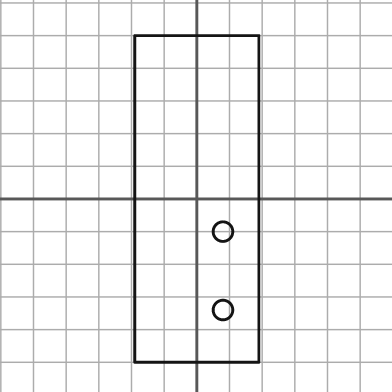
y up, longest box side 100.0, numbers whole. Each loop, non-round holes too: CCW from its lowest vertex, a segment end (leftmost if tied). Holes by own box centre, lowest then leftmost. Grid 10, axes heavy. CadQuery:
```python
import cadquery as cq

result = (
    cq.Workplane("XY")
    .moveTo(-19.0, -50.0)
    .lineTo(19.0, -50.0)
    .lineTo(19.0, 50.0)
    .lineTo(-19.0, 50.0)
    .close()
    .moveTo(8.0, -34.0)
    .circle(3.0)
    .moveTo(8.0, -10.0)
    .circle(3.0)
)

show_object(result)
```